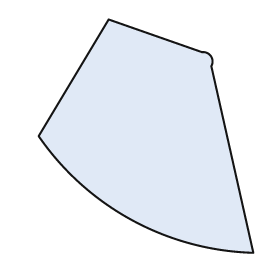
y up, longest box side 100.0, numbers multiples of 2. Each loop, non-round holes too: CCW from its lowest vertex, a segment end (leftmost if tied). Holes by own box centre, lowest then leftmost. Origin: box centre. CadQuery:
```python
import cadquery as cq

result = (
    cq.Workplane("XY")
    .moveTo(46.0, -50.0)
    .lineTo(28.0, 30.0)
    .threePointArc((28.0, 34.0), (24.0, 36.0))
    .lineTo(-16.0, 50.0)
    .lineTo(-46.0, 0.0)
    .threePointArc((-6.0, -36.0), (46.0, -50.0))
    .close()
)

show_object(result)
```